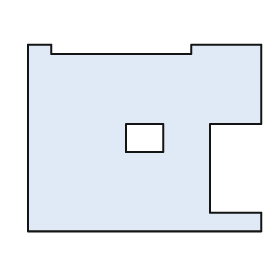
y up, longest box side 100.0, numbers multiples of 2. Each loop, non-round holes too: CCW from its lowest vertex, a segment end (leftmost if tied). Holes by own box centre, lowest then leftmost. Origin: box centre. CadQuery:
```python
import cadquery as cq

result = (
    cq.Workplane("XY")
    .moveTo(-50.0, -40.0)
    .lineTo(50.0, -40.0)
    .lineTo(50.0, -32.0)
    .lineTo(28.0, -32.0)
    .lineTo(28.0, 6.0)
    .lineTo(50.0, 6.0)
    .lineTo(50.0, 40.0)
    .lineTo(20.0, 40.0)
    .lineTo(20.0, 36.0)
    .lineTo(-40.0, 36.0)
    .lineTo(-40.0, 40.0)
    .lineTo(-50.0, 40.0)
    .close()
    .moveTo(-8.0, -6.0)
    .lineTo(8.0, -6.0)
    .lineTo(8.0, 6.0)
    .lineTo(-8.0, 6.0)
    .close()
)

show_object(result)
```